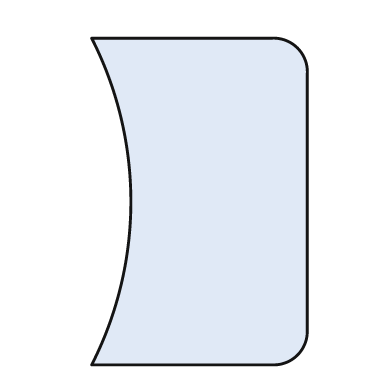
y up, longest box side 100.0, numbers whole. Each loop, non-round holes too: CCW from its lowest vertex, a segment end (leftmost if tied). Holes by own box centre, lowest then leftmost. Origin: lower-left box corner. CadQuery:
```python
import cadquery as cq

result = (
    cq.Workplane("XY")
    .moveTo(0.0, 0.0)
    .lineTo(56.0, 0.0)
    .threePointArc((63.0, 3.0), (66.0, 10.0))
    .lineTo(66.0, 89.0)
    .threePointArc((63.0, 97.0), (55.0, 100.0))
    .lineTo(0.0, 100.0)
    .threePointArc((12.0, 50.0), (0.0, 0.0))
    .close()
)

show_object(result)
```